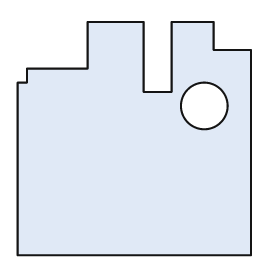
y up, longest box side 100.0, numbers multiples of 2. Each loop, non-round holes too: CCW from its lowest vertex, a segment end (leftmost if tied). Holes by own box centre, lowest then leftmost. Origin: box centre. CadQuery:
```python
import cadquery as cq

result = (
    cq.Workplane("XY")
    .moveTo(-50.0, -50.0)
    .lineTo(50.0, -50.0)
    .lineTo(50.0, 38.0)
    .lineTo(34.0, 38.0)
    .lineTo(34.0, 50.0)
    .lineTo(16.0, 50.0)
    .lineTo(16.0, 20.0)
    .lineTo(4.0, 20.0)
    .lineTo(4.0, 50.0)
    .lineTo(-20.0, 50.0)
    .lineTo(-20.0, 30.0)
    .lineTo(-46.0, 30.0)
    .lineTo(-46.0, 24.0)
    .lineTo(-50.0, 24.0)
    .close()
    .moveTo(30.0, 14.0)
    .circle(10.0)
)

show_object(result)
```